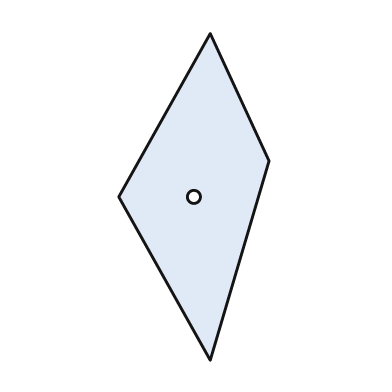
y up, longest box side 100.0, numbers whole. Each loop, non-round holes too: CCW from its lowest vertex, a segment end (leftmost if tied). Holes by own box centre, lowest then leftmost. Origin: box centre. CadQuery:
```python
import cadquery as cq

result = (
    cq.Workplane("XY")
    .moveTo(5.0, -50.0)
    .lineTo(23.0, 11.0)
    .lineTo(5.0, 50.0)
    .lineTo(-23.0, 0.0)
    .close()
    .moveTo(0.0, 0.0)
    .circle(2.0)
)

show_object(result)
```